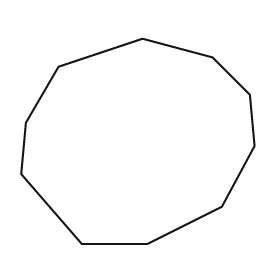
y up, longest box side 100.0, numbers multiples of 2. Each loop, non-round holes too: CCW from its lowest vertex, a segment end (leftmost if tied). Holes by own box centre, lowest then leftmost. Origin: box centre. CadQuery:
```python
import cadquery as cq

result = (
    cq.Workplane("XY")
    .moveTo(-24.0, -44.0)
    .lineTo(4.0, -44.0)
    .lineTo(36.0, -28.0)
    .lineTo(50.0, -2.0)
    .lineTo(48.0, 20.0)
    .lineTo(32.0, 36.0)
    .lineTo(2.0, 44.0)
    .lineTo(-34.0, 32.0)
    .lineTo(-48.0, 8.0)
    .lineTo(-50.0, -14.0)
    .close()
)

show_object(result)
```